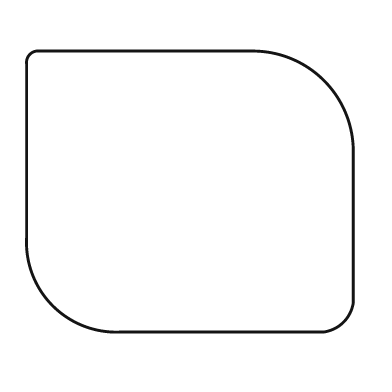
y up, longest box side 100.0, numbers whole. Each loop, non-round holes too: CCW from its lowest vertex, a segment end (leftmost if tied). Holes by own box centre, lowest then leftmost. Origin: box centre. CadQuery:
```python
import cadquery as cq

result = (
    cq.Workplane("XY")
    .moveTo(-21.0, -43.0)
    .lineTo(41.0, -43.0)
    .threePointArc((47.0, -40.0), (50.0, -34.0))
    .lineTo(50.0, 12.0)
    .threePointArc((41.0, 34.0), (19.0, 43.0))
    .lineTo(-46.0, 43.0)
    .threePointArc((-49.0, 42.0), (-50.0, 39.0))
    .lineTo(-50.0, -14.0)
    .threePointArc((-42.0, -35.0), (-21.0, -43.0))
    .close()
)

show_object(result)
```